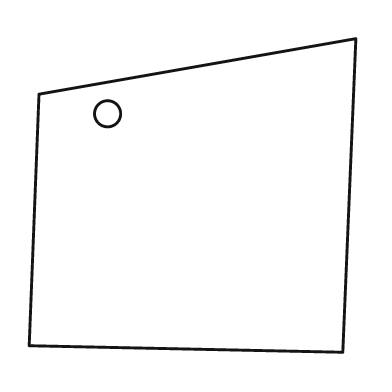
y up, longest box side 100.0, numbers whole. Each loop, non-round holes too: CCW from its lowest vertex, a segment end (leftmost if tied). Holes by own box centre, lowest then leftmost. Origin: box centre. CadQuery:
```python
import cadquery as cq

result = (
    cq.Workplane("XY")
    .moveTo(46.0, -48.0)
    .lineTo(50.0, 48.0)
    .lineTo(-47.0, 31.0)
    .lineTo(-50.0, -46.0)
    .close()
    .moveTo(-26.0, 25.0)
    .circle(4.0)
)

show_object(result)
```